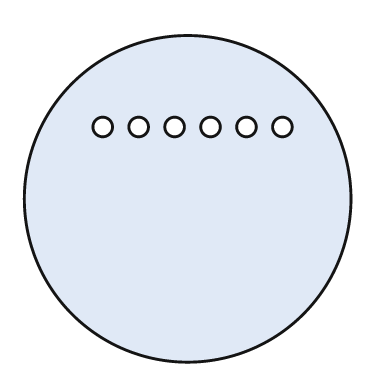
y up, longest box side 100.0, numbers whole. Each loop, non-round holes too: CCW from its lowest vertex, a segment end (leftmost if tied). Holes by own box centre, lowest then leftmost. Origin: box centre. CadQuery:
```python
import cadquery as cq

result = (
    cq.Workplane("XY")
    .moveTo(0.0, 0.0)
    .circle(50.0)
    .moveTo(-26.0, 22.0)
    .circle(3.0)
    .moveTo(-15.0, 22.0)
    .circle(3.0)
    .moveTo(-4.0, 22.0)
    .circle(3.0)
    .moveTo(7.0, 22.0)
    .circle(3.0)
    .moveTo(18.0, 22.0)
    .circle(3.0)
    .moveTo(29.0, 22.0)
    .circle(3.0)
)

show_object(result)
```